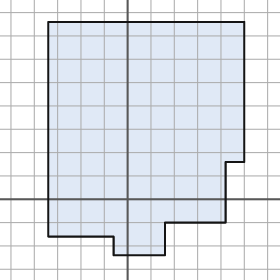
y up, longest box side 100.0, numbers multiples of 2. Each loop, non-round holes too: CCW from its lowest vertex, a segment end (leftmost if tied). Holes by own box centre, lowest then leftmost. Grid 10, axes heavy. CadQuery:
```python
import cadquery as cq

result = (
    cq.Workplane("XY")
    .moveTo(-6.0, -24.0)
    .lineTo(16.0, -24.0)
    .lineTo(16.0, -10.0)
    .lineTo(42.0, -10.0)
    .lineTo(42.0, 16.0)
    .lineTo(50.0, 16.0)
    .lineTo(50.0, 76.0)
    .lineTo(-34.0, 76.0)
    .lineTo(-34.0, -16.0)
    .lineTo(-6.0, -16.0)
    .close()
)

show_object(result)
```